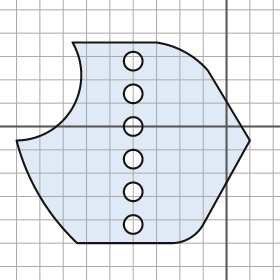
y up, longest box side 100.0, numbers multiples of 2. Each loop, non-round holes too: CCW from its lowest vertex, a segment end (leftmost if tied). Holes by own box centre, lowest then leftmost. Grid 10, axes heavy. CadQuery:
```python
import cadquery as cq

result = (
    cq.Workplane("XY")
    .moveTo(-64.0, -50.0)
    .lineTo(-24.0, -50.0)
    .threePointArc((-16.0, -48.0), (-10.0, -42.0))
    .lineTo(10.0, -6.0)
    .lineTo(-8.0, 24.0)
    .threePointArc((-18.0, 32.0), (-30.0, 36.0))
    .lineTo(-66.0, 36.0)
    .threePointArc((-66.0, 8.0), (-90.0, -6.0))
    .threePointArc((-80.0, -30.0), (-64.0, -50.0))
    .close()
    .moveTo(-40.0, -42.0)
    .circle(4.0)
    .moveTo(-40.0, -28.0)
    .circle(4.0)
    .moveTo(-40.0, -14.0)
    .circle(4.0)
    .moveTo(-40.0, 0.0)
    .circle(4.0)
    .moveTo(-40.0, 14.0)
    .circle(4.0)
    .moveTo(-40.0, 28.0)
    .circle(4.0)
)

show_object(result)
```